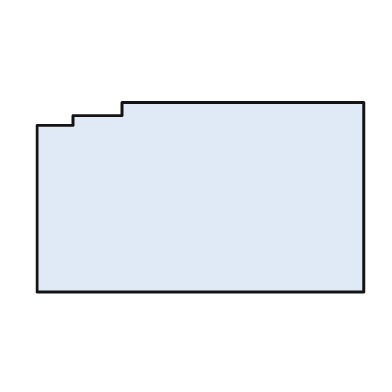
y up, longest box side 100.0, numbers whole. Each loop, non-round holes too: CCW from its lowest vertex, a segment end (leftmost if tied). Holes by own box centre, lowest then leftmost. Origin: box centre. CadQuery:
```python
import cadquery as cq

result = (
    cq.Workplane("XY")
    .moveTo(-50.0, -29.0)
    .lineTo(50.0, -29.0)
    .lineTo(50.0, 29.0)
    .lineTo(-24.0, 29.0)
    .lineTo(-24.0, 25.0)
    .lineTo(-39.0, 25.0)
    .lineTo(-39.0, 22.0)
    .lineTo(-50.0, 22.0)
    .close()
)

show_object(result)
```